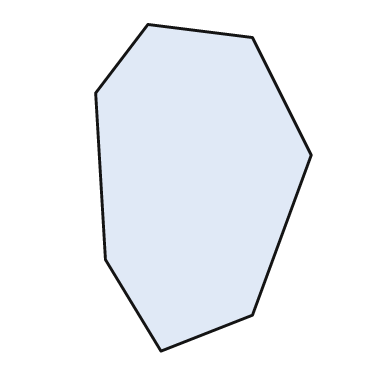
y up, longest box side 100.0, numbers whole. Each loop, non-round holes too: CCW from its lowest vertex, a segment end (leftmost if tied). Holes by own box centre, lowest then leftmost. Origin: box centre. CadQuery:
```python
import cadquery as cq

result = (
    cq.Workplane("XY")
    .moveTo(-13.0, -50.0)
    .lineTo(15.0, -39.0)
    .lineTo(33.0, 10.0)
    .lineTo(15.0, 46.0)
    .lineTo(-17.0, 50.0)
    .lineTo(-33.0, 29.0)
    .lineTo(-30.0, -22.0)
    .close()
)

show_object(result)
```